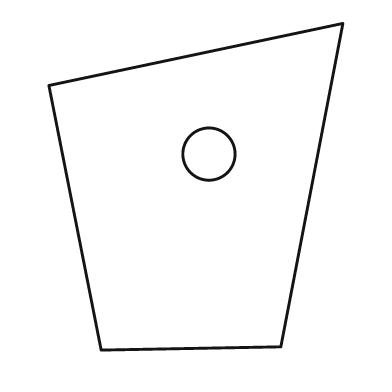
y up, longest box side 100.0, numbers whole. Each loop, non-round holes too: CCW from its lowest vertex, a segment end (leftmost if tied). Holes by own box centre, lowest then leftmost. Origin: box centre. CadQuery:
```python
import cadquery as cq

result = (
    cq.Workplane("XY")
    .moveTo(-29.0, -50.0)
    .lineTo(26.0, -49.0)
    .lineTo(45.0, 50.0)
    .lineTo(-45.0, 31.0)
    .close()
    .moveTo(4.0, 10.0)
    .circle(8.0)
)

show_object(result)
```